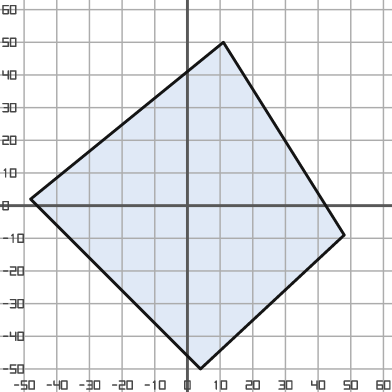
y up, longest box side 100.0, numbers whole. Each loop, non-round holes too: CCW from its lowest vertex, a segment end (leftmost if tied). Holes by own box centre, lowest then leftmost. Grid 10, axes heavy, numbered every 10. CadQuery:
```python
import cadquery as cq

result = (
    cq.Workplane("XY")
    .moveTo(4.0, -50.0)
    .lineTo(48.0, -9.0)
    .lineTo(11.0, 50.0)
    .lineTo(-48.0, 2.0)
    .close()
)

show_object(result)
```